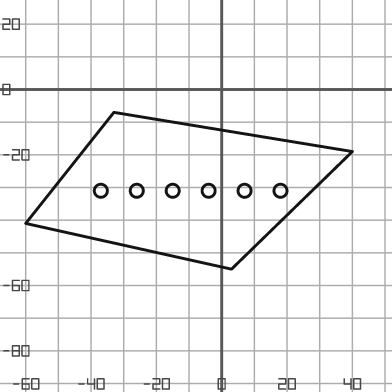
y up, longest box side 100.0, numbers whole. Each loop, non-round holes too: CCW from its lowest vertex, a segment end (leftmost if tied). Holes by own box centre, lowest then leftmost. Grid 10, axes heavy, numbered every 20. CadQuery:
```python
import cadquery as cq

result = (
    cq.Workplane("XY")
    .moveTo(3.0, -55.0)
    .lineTo(40.0, -19.0)
    .lineTo(-33.0, -7.0)
    .lineTo(-60.0, -41.0)
    .close()
    .moveTo(-37.0, -31.0)
    .circle(2.0)
    .moveTo(-26.0, -31.0)
    .circle(2.0)
    .moveTo(-15.0, -31.0)
    .circle(2.0)
    .moveTo(-4.0, -31.0)
    .circle(2.0)
    .moveTo(7.0, -31.0)
    .circle(2.0)
    .moveTo(18.0, -31.0)
    .circle(2.0)
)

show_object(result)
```